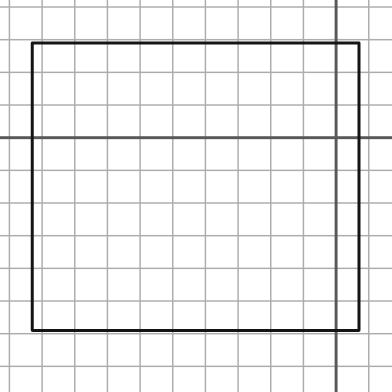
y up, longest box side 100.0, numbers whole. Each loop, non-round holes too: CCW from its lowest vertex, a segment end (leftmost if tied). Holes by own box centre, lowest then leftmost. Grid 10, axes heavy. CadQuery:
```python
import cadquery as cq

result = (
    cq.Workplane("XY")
    .moveTo(-93.0, -59.0)
    .lineTo(7.0, -59.0)
    .lineTo(7.0, 29.0)
    .lineTo(-93.0, 29.0)
    .close()
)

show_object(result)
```